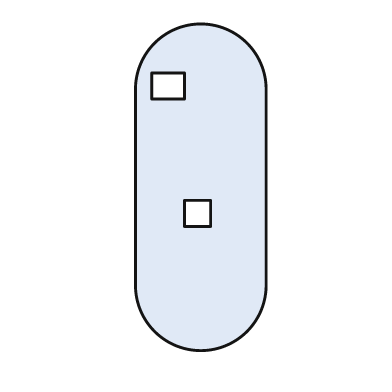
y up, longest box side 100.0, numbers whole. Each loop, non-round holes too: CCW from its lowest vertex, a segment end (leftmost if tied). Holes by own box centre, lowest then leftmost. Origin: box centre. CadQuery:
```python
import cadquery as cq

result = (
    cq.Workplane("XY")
    .moveTo(-20.0, -30.0)
    .threePointArc((0.0, -50.0), (20.0, -30.0))
    .lineTo(20.0, 30.0)
    .threePointArc((0.0, 50.0), (-20.0, 30.0))
    .close()
    .moveTo(-5.0, -12.0)
    .lineTo(3.0, -12.0)
    .lineTo(3.0, -4.0)
    .lineTo(-5.0, -4.0)
    .close()
    .moveTo(-15.0, 27.0)
    .lineTo(-5.0, 27.0)
    .lineTo(-5.0, 35.0)
    .lineTo(-15.0, 35.0)
    .close()
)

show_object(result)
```